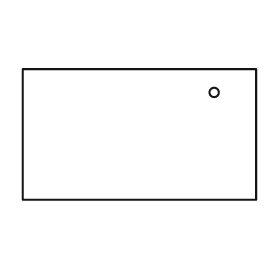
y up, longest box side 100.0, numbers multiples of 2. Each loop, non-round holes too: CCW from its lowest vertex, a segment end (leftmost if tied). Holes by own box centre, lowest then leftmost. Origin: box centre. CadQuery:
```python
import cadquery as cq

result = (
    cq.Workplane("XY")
    .moveTo(-50.0, -28.0)
    .lineTo(50.0, -28.0)
    .lineTo(50.0, 28.0)
    .lineTo(-50.0, 28.0)
    .close()
    .moveTo(32.0, 18.0)
    .circle(2.0)
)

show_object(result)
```